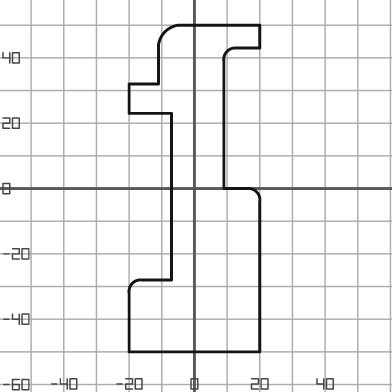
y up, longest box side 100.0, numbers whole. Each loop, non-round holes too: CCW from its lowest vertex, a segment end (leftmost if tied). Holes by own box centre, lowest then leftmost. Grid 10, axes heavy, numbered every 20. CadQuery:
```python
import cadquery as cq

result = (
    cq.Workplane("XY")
    .moveTo(-20.0, -50.0)
    .lineTo(20.0, -50.0)
    .lineTo(20.0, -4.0)
    .threePointArc((19.0, -1.0), (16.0, 0.0))
    .lineTo(9.0, 0.0)
    .lineTo(9.0, 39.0)
    .threePointArc((10.0, 42.0), (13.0, 43.0))
    .lineTo(20.0, 43.0)
    .lineTo(20.0, 50.0)
    .lineTo(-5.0, 50.0)
    .threePointArc((-9.0, 48.0), (-11.0, 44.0))
    .lineTo(-11.0, 32.0)
    .lineTo(-20.0, 32.0)
    .lineTo(-20.0, 23.0)
    .lineTo(-7.0, 23.0)
    .lineTo(-7.0, -28.0)
    .lineTo(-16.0, -28.0)
    .threePointArc((-19.0, -29.0), (-20.0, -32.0))
    .close()
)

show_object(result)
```